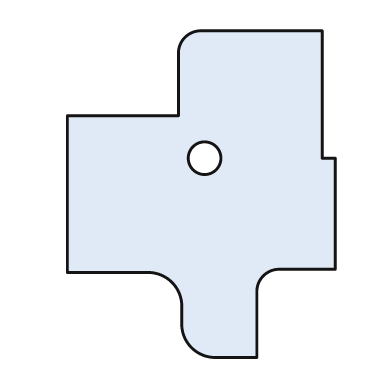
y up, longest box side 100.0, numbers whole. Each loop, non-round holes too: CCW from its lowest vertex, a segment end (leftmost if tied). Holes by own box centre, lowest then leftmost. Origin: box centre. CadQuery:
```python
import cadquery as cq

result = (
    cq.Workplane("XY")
    .moveTo(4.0, -50.0)
    .lineTo(17.0, -50.0)
    .lineTo(17.0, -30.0)
    .threePointArc((19.0, -25.0), (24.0, -23.0))
    .lineTo(41.0, -23.0)
    .lineTo(41.0, 11.0)
    .lineTo(37.0, 11.0)
    .lineTo(37.0, 50.0)
    .lineTo(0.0, 50.0)
    .threePointArc((-5.0, 48.0), (-7.0, 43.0))
    .lineTo(-7.0, 24.0)
    .lineTo(-41.0, 24.0)
    .lineTo(-41.0, -24.0)
    .lineTo(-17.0, -24.0)
    .threePointArc((-9.0, -27.0), (-6.0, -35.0))
    .lineTo(-6.0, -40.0)
    .threePointArc((-3.0, -47.0), (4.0, -50.0))
    .close()
    .moveTo(1.0, 11.0)
    .circle(5.0)
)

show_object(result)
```